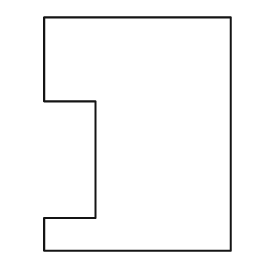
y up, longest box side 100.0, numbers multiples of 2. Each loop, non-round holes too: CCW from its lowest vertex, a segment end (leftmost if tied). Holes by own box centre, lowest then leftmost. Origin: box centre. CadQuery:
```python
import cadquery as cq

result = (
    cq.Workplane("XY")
    .moveTo(-40.0, -50.0)
    .lineTo(40.0, -50.0)
    .lineTo(40.0, 50.0)
    .lineTo(-40.0, 50.0)
    .lineTo(-40.0, 14.0)
    .lineTo(-18.0, 14.0)
    .lineTo(-18.0, -36.0)
    .lineTo(-40.0, -36.0)
    .close()
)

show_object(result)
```